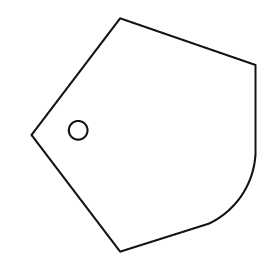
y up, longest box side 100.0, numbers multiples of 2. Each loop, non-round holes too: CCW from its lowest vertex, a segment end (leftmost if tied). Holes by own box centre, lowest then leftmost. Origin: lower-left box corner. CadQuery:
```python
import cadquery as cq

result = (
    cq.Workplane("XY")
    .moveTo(38.0, 0.0)
    .lineTo(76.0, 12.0)
    .threePointArc((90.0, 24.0), (96.0, 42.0))
    .lineTo(96.0, 80.0)
    .lineTo(38.0, 100.0)
    .lineTo(0.0, 50.0)
    .close()
    .moveTo(20.0, 52.0)
    .circle(4.0)
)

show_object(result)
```